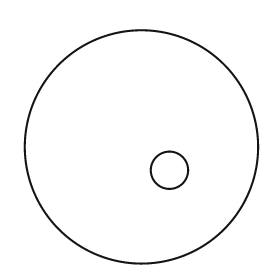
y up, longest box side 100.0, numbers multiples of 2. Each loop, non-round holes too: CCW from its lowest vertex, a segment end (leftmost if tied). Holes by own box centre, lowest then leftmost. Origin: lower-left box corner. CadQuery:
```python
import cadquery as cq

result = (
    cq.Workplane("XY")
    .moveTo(50.0, 50.0)
    .circle(50.0)
    .moveTo(62.0, 40.0)
    .circle(8.0)
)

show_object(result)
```